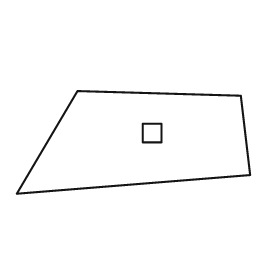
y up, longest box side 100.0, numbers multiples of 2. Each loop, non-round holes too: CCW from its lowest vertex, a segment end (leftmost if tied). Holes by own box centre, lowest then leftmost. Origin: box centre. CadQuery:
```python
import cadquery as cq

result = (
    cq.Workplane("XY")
    .moveTo(-50.0, -22.0)
    .lineTo(50.0, -14.0)
    .lineTo(46.0, 20.0)
    .lineTo(-24.0, 22.0)
    .close()
    .moveTo(4.0, 0.0)
    .lineTo(12.0, 0.0)
    .lineTo(12.0, 8.0)
    .lineTo(4.0, 8.0)
    .close()
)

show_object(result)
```